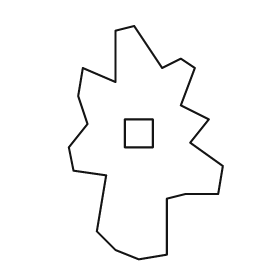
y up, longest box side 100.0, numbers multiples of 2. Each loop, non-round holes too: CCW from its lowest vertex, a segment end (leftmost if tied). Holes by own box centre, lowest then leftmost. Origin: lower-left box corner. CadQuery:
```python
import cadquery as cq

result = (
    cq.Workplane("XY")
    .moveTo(30.0, 0.0)
    .lineTo(42.0, 2.0)
    .lineTo(42.0, 26.0)
    .lineTo(50.0, 28.0)
    .lineTo(64.0, 28.0)
    .lineTo(66.0, 40.0)
    .lineTo(52.0, 50.0)
    .lineTo(60.0, 60.0)
    .lineTo(48.0, 66.0)
    .lineTo(54.0, 82.0)
    .lineTo(48.0, 86.0)
    .lineTo(40.0, 82.0)
    .lineTo(28.0, 100.0)
    .lineTo(20.0, 98.0)
    .lineTo(20.0, 76.0)
    .lineTo(6.0, 82.0)
    .lineTo(4.0, 70.0)
    .lineTo(8.0, 58.0)
    .lineTo(0.0, 48.0)
    .lineTo(2.0, 38.0)
    .lineTo(16.0, 36.0)
    .lineTo(12.0, 12.0)
    .lineTo(20.0, 4.0)
    .close()
    .moveTo(24.0, 48.0)
    .lineTo(36.0, 48.0)
    .lineTo(36.0, 60.0)
    .lineTo(24.0, 60.0)
    .close()
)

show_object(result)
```